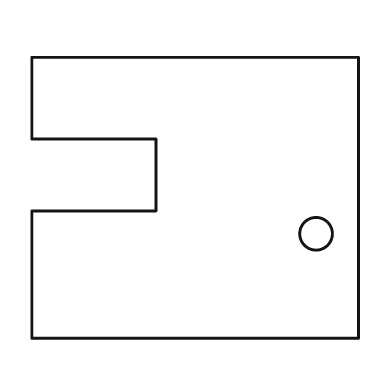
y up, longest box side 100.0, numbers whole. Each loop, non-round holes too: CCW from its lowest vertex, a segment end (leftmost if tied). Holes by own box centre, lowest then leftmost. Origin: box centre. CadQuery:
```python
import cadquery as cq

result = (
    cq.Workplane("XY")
    .moveTo(-50.0, -43.0)
    .lineTo(50.0, -43.0)
    .lineTo(50.0, 43.0)
    .lineTo(-50.0, 43.0)
    .lineTo(-50.0, 18.0)
    .lineTo(-12.0, 18.0)
    .lineTo(-12.0, -4.0)
    .lineTo(-50.0, -4.0)
    .close()
    .moveTo(37.0, -11.0)
    .circle(5.0)
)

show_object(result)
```